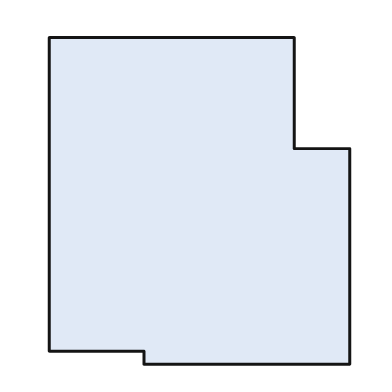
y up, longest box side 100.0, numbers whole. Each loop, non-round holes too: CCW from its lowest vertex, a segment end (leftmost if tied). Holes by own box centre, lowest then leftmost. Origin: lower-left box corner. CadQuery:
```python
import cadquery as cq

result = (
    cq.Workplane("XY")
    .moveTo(29.0, 0.0)
    .lineTo(92.0, 0.0)
    .lineTo(92.0, 66.0)
    .lineTo(75.0, 66.0)
    .lineTo(75.0, 100.0)
    .lineTo(0.0, 100.0)
    .lineTo(0.0, 4.0)
    .lineTo(29.0, 4.0)
    .close()
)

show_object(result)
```